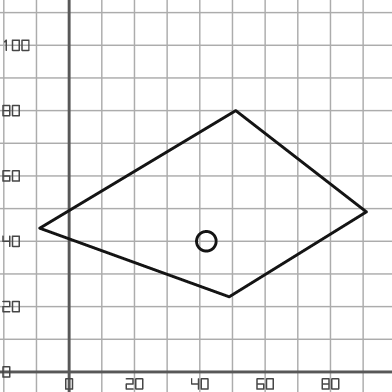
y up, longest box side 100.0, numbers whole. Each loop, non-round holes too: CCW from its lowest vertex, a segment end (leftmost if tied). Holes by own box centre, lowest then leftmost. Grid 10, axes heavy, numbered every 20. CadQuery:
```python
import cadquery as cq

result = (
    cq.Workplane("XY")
    .moveTo(49.0, 23.0)
    .lineTo(91.0, 49.0)
    .lineTo(51.0, 80.0)
    .lineTo(-9.0, 44.0)
    .close()
    .moveTo(42.0, 40.0)
    .circle(3.0)
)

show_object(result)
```